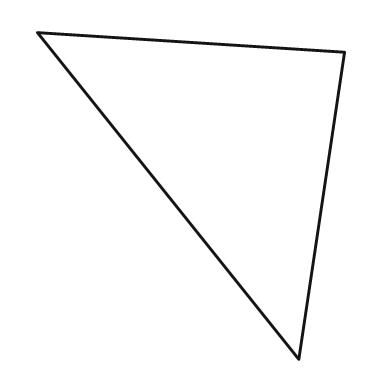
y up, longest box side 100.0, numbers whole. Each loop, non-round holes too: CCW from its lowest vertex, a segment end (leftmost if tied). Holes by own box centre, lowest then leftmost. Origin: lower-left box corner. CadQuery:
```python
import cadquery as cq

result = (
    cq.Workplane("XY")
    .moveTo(80.0, 0.0)
    .lineTo(94.0, 94.0)
    .lineTo(0.0, 100.0)
    .close()
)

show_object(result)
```